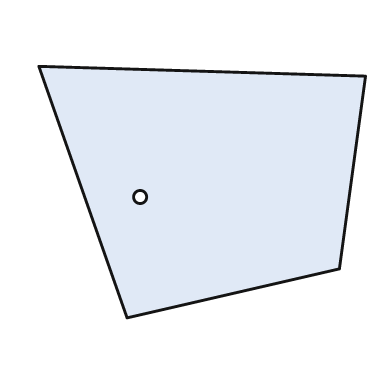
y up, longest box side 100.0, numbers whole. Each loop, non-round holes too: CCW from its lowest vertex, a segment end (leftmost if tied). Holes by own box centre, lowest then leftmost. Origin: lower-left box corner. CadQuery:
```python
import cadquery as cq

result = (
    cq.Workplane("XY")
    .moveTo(27.0, 0.0)
    .lineTo(92.0, 15.0)
    .lineTo(100.0, 74.0)
    .lineTo(0.0, 77.0)
    .close()
    .moveTo(31.0, 37.0)
    .circle(2.0)
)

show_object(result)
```